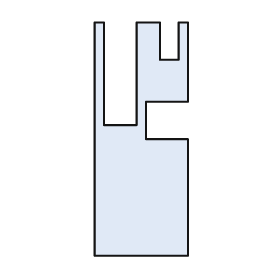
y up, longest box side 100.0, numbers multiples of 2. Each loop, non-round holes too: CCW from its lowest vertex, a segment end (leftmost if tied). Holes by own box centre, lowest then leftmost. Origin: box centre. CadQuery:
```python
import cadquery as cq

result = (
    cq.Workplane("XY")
    .moveTo(-20.0, -50.0)
    .lineTo(20.0, -50.0)
    .lineTo(20.0, 0.0)
    .lineTo(2.0, 0.0)
    .lineTo(2.0, 16.0)
    .lineTo(20.0, 16.0)
    .lineTo(20.0, 50.0)
    .lineTo(16.0, 50.0)
    .lineTo(16.0, 34.0)
    .lineTo(8.0, 34.0)
    .lineTo(8.0, 50.0)
    .lineTo(-2.0, 50.0)
    .lineTo(-2.0, 6.0)
    .lineTo(-16.0, 6.0)
    .lineTo(-16.0, 50.0)
    .lineTo(-20.0, 50.0)
    .close()
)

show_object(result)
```